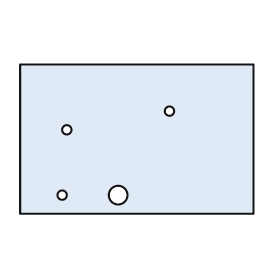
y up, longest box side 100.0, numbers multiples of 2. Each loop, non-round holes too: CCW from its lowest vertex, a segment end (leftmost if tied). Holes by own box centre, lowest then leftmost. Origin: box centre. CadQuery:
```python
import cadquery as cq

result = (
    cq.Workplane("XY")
    .moveTo(-50.0, -32.0)
    .lineTo(50.0, -32.0)
    .lineTo(50.0, 32.0)
    .lineTo(-50.0, 32.0)
    .close()
    .moveTo(-32.0, -24.0)
    .circle(2.0)
    .moveTo(-8.0, -24.0)
    .circle(4.0)
    .moveTo(-30.0, 4.0)
    .circle(2.0)
    .moveTo(14.0, 12.0)
    .circle(2.0)
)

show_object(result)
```